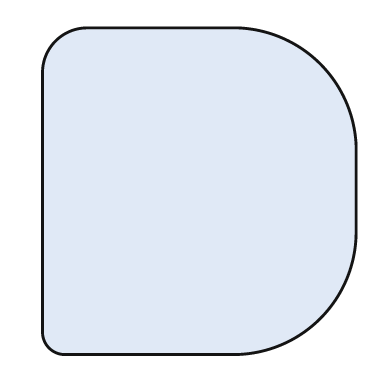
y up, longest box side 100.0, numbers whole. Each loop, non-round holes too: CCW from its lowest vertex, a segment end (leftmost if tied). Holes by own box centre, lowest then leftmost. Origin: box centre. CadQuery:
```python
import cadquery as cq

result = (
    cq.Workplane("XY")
    .moveTo(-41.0, -50.0)
    .lineTo(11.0, -50.0)
    .threePointArc((37.0, -39.0), (48.0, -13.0))
    .lineTo(48.0, 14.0)
    .threePointArc((37.0, 39.0), (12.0, 50.0))
    .lineTo(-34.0, 50.0)
    .threePointArc((-44.0, 46.0), (-48.0, 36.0))
    .lineTo(-48.0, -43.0)
    .threePointArc((-46.0, -48.0), (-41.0, -50.0))
    .close()
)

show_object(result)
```